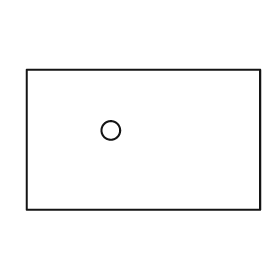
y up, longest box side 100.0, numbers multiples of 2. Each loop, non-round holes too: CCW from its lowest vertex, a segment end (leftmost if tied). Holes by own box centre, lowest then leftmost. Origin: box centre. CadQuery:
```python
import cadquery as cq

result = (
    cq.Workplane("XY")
    .moveTo(-50.0, -30.0)
    .lineTo(50.0, -30.0)
    .lineTo(50.0, 30.0)
    .lineTo(-50.0, 30.0)
    .close()
    .moveTo(-14.0, 4.0)
    .circle(4.0)
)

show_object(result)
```